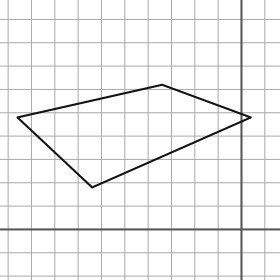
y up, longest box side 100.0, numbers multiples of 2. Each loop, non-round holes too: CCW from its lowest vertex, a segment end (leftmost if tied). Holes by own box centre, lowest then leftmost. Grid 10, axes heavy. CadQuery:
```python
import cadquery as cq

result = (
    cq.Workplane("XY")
    .moveTo(-64.0, 18.0)
    .lineTo(4.0, 48.0)
    .lineTo(-34.0, 62.0)
    .lineTo(-96.0, 48.0)
    .close()
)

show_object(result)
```